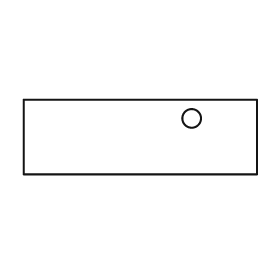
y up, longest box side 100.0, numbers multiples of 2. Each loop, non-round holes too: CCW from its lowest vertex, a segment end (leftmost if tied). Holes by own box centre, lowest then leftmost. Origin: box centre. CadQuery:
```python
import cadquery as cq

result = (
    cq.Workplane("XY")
    .moveTo(-50.0, -16.0)
    .lineTo(50.0, -16.0)
    .lineTo(50.0, 16.0)
    .lineTo(-50.0, 16.0)
    .close()
    .moveTo(22.0, 8.0)
    .circle(4.0)
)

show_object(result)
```